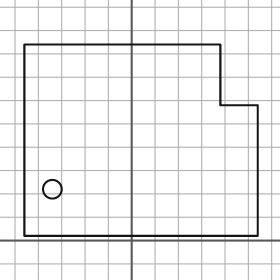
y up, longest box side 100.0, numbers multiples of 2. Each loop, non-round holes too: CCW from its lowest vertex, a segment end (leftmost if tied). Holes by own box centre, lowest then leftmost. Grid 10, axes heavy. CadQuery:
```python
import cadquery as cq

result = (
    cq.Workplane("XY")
    .moveTo(-46.0, 2.0)
    .lineTo(54.0, 2.0)
    .lineTo(54.0, 58.0)
    .lineTo(38.0, 58.0)
    .lineTo(38.0, 84.0)
    .lineTo(-46.0, 84.0)
    .close()
    .moveTo(-34.0, 22.0)
    .circle(4.0)
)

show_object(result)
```